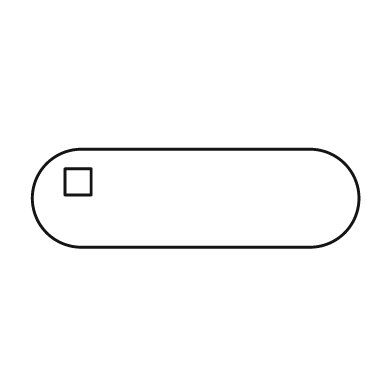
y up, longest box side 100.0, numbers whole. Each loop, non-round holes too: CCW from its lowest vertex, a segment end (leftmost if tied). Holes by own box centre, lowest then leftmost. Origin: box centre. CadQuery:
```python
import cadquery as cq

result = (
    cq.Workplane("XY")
    .moveTo(-35.0, -15.0)
    .lineTo(35.0, -15.0)
    .threePointArc((50.0, 0.0), (35.0, 15.0))
    .lineTo(-35.0, 15.0)
    .threePointArc((-50.0, 0.0), (-35.0, -15.0))
    .close()
    .moveTo(-40.0, 1.0)
    .lineTo(-32.0, 1.0)
    .lineTo(-32.0, 9.0)
    .lineTo(-40.0, 9.0)
    .close()
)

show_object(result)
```